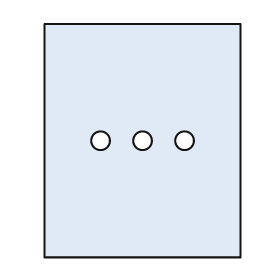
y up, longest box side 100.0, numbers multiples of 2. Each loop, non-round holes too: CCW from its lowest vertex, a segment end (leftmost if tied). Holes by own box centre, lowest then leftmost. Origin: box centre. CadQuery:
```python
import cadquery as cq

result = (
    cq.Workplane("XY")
    .moveTo(-42.0, -50.0)
    .lineTo(42.0, -50.0)
    .lineTo(42.0, 50.0)
    .lineTo(-42.0, 50.0)
    .close()
    .moveTo(-18.0, 0.0)
    .circle(4.0)
    .moveTo(0.0, 0.0)
    .circle(4.0)
    .moveTo(18.0, 0.0)
    .circle(4.0)
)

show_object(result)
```